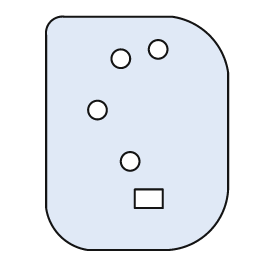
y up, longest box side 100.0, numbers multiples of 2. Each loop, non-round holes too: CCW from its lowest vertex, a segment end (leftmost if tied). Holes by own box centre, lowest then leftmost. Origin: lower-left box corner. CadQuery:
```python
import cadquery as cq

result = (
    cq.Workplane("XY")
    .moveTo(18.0, 0.0)
    .lineTo(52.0, 0.0)
    .threePointArc((70.0, 8.0), (78.0, 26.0))
    .lineTo(78.0, 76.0)
    .threePointArc((70.0, 92.0), (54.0, 100.0))
    .lineTo(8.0, 100.0)
    .threePointArc((2.0, 98.0), (0.0, 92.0))
    .lineTo(0.0, 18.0)
    .threePointArc((6.0, 6.0), (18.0, 0.0))
    .close()
    .moveTo(38.0, 18.0)
    .lineTo(50.0, 18.0)
    .lineTo(50.0, 26.0)
    .lineTo(38.0, 26.0)
    .close()
    .moveTo(36.0, 38.0)
    .circle(4.0)
    .moveTo(22.0, 60.0)
    .circle(4.0)
    .moveTo(32.0, 82.0)
    .circle(4.0)
    .moveTo(48.0, 86.0)
    .circle(4.0)
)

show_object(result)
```